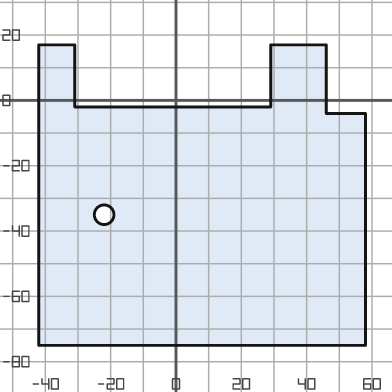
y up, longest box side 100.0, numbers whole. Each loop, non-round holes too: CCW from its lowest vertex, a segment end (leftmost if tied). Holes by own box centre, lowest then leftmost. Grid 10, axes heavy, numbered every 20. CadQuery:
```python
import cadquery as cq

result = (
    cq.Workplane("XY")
    .moveTo(-42.0, -75.0)
    .lineTo(58.0, -75.0)
    .lineTo(58.0, -4.0)
    .lineTo(46.0, -4.0)
    .lineTo(46.0, 17.0)
    .lineTo(29.0, 17.0)
    .lineTo(29.0, -2.0)
    .lineTo(-31.0, -2.0)
    .lineTo(-31.0, 17.0)
    .lineTo(-42.0, 17.0)
    .close()
    .moveTo(-22.0, -35.0)
    .circle(3.0)
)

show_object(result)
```